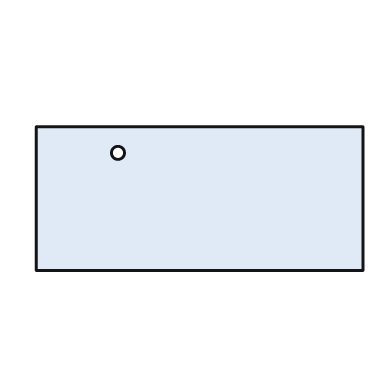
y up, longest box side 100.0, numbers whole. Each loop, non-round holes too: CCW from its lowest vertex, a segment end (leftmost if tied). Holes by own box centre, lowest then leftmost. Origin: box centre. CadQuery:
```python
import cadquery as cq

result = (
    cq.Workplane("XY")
    .moveTo(-50.0, -22.0)
    .lineTo(50.0, -22.0)
    .lineTo(50.0, 22.0)
    .lineTo(-50.0, 22.0)
    .close()
    .moveTo(-25.0, 14.0)
    .circle(2.0)
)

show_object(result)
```